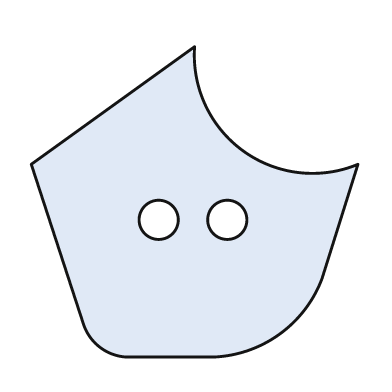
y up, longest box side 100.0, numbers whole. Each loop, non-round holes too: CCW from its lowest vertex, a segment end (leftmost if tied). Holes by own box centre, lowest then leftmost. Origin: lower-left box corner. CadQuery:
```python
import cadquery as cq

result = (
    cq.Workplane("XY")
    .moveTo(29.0, 0.0)
    .lineTo(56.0, 0.0)
    .threePointArc((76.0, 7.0), (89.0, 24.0))
    .lineTo(100.0, 59.0)
    .threePointArc((65.0, 63.0), (50.0, 95.0))
    .lineTo(0.0, 59.0)
    .lineTo(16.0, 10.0)
    .threePointArc((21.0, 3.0), (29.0, 0.0))
    .close()
    .moveTo(39.0, 42.0)
    .circle(6.0)
    .moveTo(60.0, 42.0)
    .circle(6.0)
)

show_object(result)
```